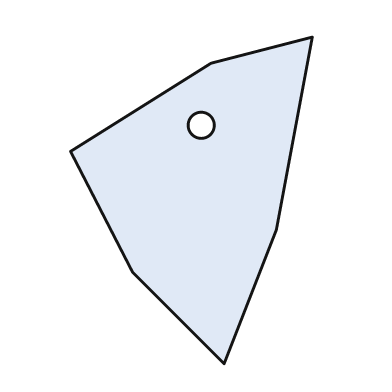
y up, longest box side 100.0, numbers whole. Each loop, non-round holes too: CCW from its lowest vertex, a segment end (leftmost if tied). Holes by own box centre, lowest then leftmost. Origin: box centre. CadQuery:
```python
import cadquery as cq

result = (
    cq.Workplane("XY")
    .moveTo(10.0, -50.0)
    .lineTo(26.0, -9.0)
    .lineTo(37.0, 50.0)
    .lineTo(6.0, 42.0)
    .lineTo(-37.0, 15.0)
    .lineTo(-18.0, -22.0)
    .close()
    .moveTo(3.0, 23.0)
    .circle(4.0)
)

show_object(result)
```